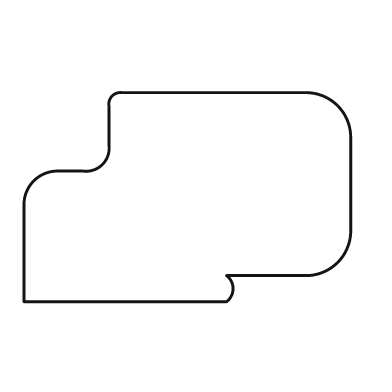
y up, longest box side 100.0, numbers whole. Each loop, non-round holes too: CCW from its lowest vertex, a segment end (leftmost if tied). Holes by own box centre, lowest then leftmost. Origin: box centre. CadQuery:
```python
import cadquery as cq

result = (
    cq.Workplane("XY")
    .moveTo(-50.0, -32.0)
    .lineTo(12.0, -32.0)
    .threePointArc((14.0, -28.0), (12.0, -24.0))
    .lineTo(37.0, -24.0)
    .threePointArc((46.0, -20.0), (50.0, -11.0))
    .lineTo(50.0, 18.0)
    .threePointArc((46.0, 28.0), (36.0, 32.0))
    .lineTo(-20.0, 32.0)
    .threePointArc((-23.0, 31.0), (-24.0, 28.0))
    .lineTo(-24.0, 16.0)
    .threePointArc((-26.0, 10.0), (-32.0, 8.0))
    .lineTo(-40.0, 8.0)
    .threePointArc((-47.0, 5.0), (-50.0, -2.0))
    .close()
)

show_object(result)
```